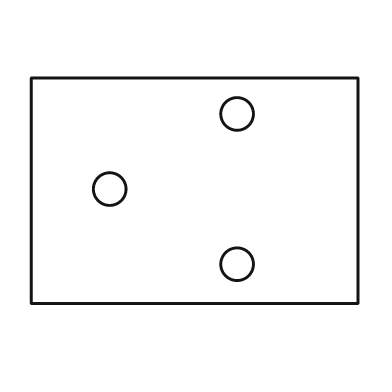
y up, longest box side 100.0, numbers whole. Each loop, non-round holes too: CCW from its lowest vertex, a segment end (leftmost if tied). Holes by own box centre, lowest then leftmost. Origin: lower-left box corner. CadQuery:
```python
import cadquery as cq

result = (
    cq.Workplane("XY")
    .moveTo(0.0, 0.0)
    .lineTo(100.0, 0.0)
    .lineTo(100.0, 69.0)
    .lineTo(0.0, 69.0)
    .close()
    .moveTo(63.0, 12.0)
    .circle(5.0)
    .moveTo(24.0, 35.0)
    .circle(5.0)
    .moveTo(63.0, 58.0)
    .circle(5.0)
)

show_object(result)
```